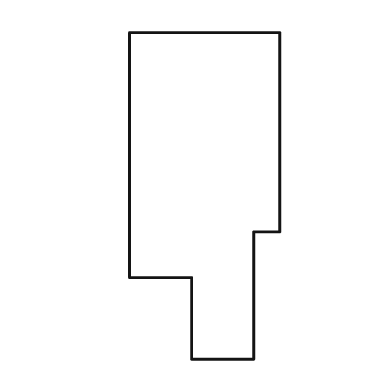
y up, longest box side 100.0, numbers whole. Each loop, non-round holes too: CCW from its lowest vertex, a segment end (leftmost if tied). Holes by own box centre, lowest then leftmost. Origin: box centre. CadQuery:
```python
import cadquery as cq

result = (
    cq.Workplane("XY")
    .moveTo(-4.0, -50.0)
    .lineTo(15.0, -50.0)
    .lineTo(15.0, -11.0)
    .lineTo(23.0, -11.0)
    .lineTo(23.0, 50.0)
    .lineTo(-23.0, 50.0)
    .lineTo(-23.0, -25.0)
    .lineTo(-4.0, -25.0)
    .close()
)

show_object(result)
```